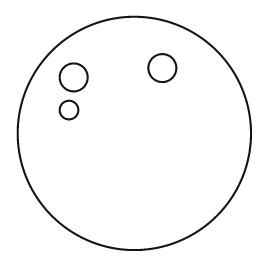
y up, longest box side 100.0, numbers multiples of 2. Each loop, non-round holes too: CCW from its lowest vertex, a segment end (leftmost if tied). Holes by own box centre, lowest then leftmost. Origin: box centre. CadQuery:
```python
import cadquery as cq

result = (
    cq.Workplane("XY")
    .moveTo(0.0, 0.0)
    .circle(50.0)
    .moveTo(-28.0, 10.0)
    .circle(4.0)
    .moveTo(-26.0, 24.0)
    .circle(6.0)
    .moveTo(12.0, 28.0)
    .circle(6.0)
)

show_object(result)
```